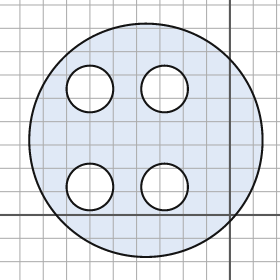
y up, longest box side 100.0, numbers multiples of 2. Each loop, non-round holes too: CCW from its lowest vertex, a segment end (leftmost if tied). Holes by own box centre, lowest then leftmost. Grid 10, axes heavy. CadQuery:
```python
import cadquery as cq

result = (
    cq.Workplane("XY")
    .moveTo(-36.0, 32.0)
    .circle(50.0)
    .moveTo(-60.0, 12.0)
    .circle(10.0)
    .moveTo(-28.0, 12.0)
    .circle(10.0)
    .moveTo(-60.0, 54.0)
    .circle(10.0)
    .moveTo(-28.0, 54.0)
    .circle(10.0)
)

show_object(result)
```